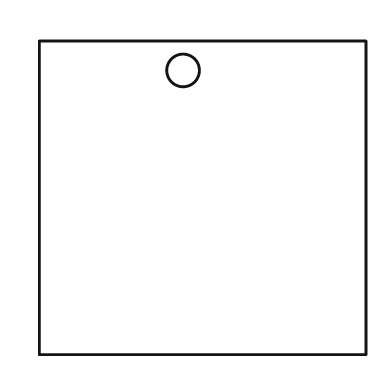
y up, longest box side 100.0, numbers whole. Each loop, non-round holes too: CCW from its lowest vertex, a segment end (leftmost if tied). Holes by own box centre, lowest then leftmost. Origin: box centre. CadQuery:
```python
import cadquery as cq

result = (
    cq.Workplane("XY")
    .moveTo(-50.0, -48.0)
    .lineTo(50.0, -48.0)
    .lineTo(50.0, 48.0)
    .lineTo(-50.0, 48.0)
    .close()
    .moveTo(-6.0, 39.0)
    .circle(5.0)
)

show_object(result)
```